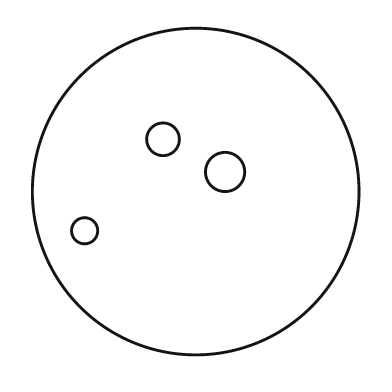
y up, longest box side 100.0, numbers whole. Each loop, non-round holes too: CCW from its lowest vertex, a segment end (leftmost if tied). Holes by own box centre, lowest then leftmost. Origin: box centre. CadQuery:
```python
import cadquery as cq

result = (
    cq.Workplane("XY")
    .moveTo(0.0, 0.0)
    .circle(50.0)
    .moveTo(-34.0, -12.0)
    .circle(4.0)
    .moveTo(9.0, 6.0)
    .circle(6.0)
    .moveTo(-10.0, 16.0)
    .circle(5.0)
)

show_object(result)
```